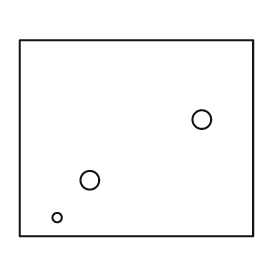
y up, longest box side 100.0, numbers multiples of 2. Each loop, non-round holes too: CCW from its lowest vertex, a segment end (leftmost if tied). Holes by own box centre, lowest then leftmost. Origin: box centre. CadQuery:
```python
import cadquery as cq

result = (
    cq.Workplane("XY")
    .moveTo(-50.0, -42.0)
    .lineTo(50.0, -42.0)
    .lineTo(50.0, 42.0)
    .lineTo(-50.0, 42.0)
    .close()
    .moveTo(-34.0, -34.0)
    .circle(2.0)
    .moveTo(-20.0, -18.0)
    .circle(4.0)
    .moveTo(28.0, 8.0)
    .circle(4.0)
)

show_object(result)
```